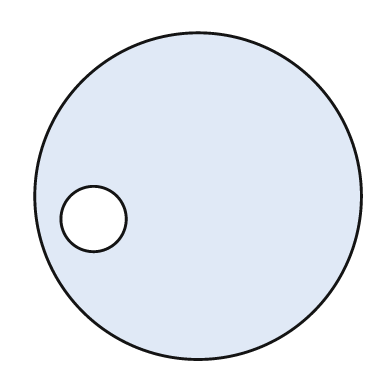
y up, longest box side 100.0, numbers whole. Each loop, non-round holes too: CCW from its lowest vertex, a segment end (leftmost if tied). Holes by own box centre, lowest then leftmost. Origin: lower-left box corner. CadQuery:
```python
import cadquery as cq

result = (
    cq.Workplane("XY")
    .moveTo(50.0, 50.0)
    .circle(50.0)
    .moveTo(18.0, 43.0)
    .circle(10.0)
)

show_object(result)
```